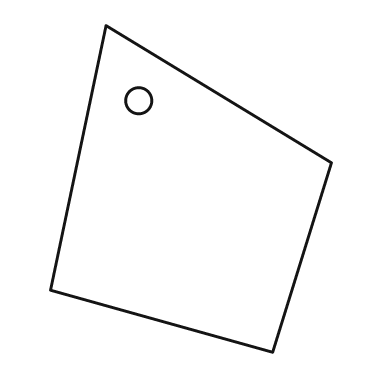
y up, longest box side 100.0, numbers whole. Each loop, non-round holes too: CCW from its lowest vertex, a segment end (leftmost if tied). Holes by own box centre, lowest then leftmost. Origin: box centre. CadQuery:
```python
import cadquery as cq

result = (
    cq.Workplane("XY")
    .moveTo(25.0, -50.0)
    .lineTo(43.0, 8.0)
    .lineTo(-26.0, 50.0)
    .lineTo(-43.0, -31.0)
    .close()
    .moveTo(-16.0, 27.0)
    .circle(4.0)
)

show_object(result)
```